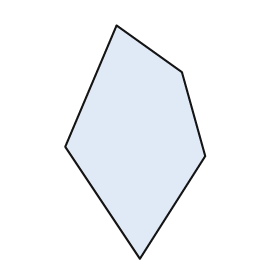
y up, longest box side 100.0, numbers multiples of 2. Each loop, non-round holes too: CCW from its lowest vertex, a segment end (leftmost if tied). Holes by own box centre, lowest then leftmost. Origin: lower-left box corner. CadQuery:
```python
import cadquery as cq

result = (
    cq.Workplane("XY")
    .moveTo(32.0, 0.0)
    .lineTo(60.0, 44.0)
    .lineTo(50.0, 80.0)
    .lineTo(22.0, 100.0)
    .lineTo(0.0, 48.0)
    .close()
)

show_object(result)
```